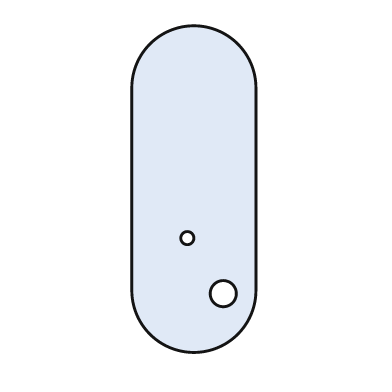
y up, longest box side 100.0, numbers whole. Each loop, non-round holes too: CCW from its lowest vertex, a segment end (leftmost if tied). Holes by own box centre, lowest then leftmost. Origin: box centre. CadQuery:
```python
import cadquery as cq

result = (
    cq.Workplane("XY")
    .moveTo(-19.0, -31.0)
    .threePointArc((0.0, -50.0), (19.0, -31.0))
    .lineTo(19.0, 31.0)
    .threePointArc((0.0, 50.0), (-19.0, 31.0))
    .close()
    .moveTo(9.0, -32.0)
    .circle(4.0)
    .moveTo(-2.0, -15.0)
    .circle(2.0)
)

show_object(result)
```